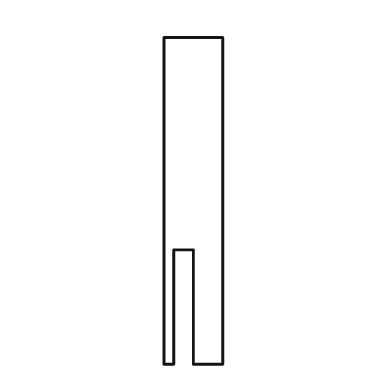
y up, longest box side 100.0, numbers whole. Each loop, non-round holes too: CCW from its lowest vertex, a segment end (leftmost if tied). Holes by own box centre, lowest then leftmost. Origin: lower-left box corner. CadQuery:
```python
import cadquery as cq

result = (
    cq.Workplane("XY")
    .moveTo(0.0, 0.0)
    .lineTo(3.0, 0.0)
    .lineTo(3.0, 35.0)
    .lineTo(9.0, 35.0)
    .lineTo(9.0, 0.0)
    .lineTo(18.0, 0.0)
    .lineTo(18.0, 100.0)
    .lineTo(0.0, 100.0)
    .close()
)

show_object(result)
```